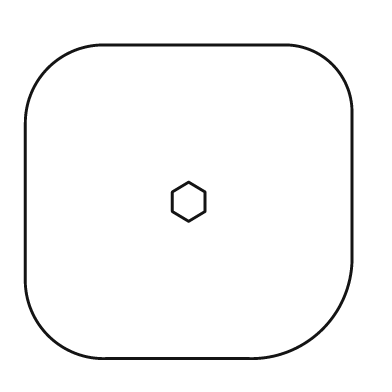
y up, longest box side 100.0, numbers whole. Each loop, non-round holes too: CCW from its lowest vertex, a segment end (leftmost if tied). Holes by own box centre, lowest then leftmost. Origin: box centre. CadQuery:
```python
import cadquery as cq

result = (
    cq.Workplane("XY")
    .moveTo(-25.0, -48.0)
    .lineTo(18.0, -48.0)
    .threePointArc((41.0, -39.0), (50.0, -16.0))
    .lineTo(50.0, 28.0)
    .threePointArc((44.0, 42.0), (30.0, 48.0))
    .lineTo(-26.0, 48.0)
    .threePointArc((-43.0, 41.0), (-50.0, 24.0))
    .lineTo(-50.0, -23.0)
    .threePointArc((-43.0, -41.0), (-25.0, -48.0))
    .close()
    .moveTo(0.0, -6.0)
    .lineTo(5.0, -3.0)
    .lineTo(5.0, 3.0)
    .lineTo(0.0, 6.0)
    .lineTo(-5.0, 3.0)
    .lineTo(-5.0, -3.0)
    .close()
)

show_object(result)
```